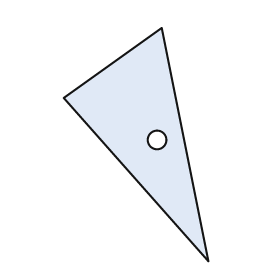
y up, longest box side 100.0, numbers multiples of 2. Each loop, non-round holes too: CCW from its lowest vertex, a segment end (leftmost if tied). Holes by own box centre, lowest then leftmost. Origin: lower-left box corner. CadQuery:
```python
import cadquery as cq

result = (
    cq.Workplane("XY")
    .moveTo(62.0, 0.0)
    .lineTo(42.0, 100.0)
    .lineTo(0.0, 70.0)
    .close()
    .moveTo(40.0, 52.0)
    .circle(4.0)
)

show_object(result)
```